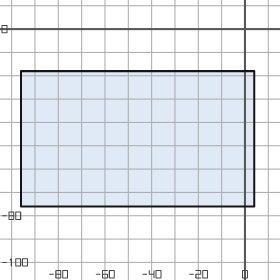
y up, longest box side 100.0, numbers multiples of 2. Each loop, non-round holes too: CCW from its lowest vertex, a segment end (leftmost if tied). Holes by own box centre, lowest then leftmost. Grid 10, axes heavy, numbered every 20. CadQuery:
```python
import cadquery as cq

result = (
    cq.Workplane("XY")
    .moveTo(-96.0, -76.0)
    .lineTo(4.0, -76.0)
    .lineTo(4.0, -18.0)
    .lineTo(-96.0, -18.0)
    .close()
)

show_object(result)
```